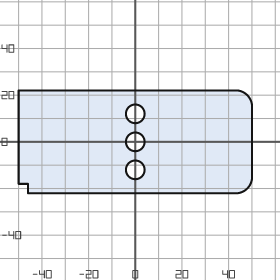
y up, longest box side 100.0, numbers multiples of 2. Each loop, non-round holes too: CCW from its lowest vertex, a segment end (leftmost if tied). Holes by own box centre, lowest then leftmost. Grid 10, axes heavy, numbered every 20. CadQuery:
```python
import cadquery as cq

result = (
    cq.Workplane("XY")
    .moveTo(-46.0, -22.0)
    .lineTo(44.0, -22.0)
    .threePointArc((48.0, -20.0), (50.0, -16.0))
    .lineTo(50.0, 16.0)
    .threePointArc((48.0, 20.0), (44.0, 22.0))
    .lineTo(-50.0, 22.0)
    .lineTo(-50.0, -18.0)
    .lineTo(-46.0, -18.0)
    .close()
    .moveTo(0.0, -12.0)
    .circle(4.0)
    .moveTo(0.0, 0.0)
    .circle(4.0)
    .moveTo(0.0, 12.0)
    .circle(4.0)
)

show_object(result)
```